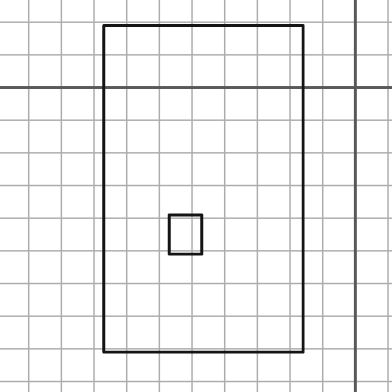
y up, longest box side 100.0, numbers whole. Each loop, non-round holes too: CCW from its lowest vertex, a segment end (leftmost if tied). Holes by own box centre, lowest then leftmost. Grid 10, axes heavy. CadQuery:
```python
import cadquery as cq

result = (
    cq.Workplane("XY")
    .moveTo(-77.0, -81.0)
    .lineTo(-16.0, -81.0)
    .lineTo(-16.0, 19.0)
    .lineTo(-77.0, 19.0)
    .close()
    .moveTo(-57.0, -51.0)
    .lineTo(-47.0, -51.0)
    .lineTo(-47.0, -39.0)
    .lineTo(-57.0, -39.0)
    .close()
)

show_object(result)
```